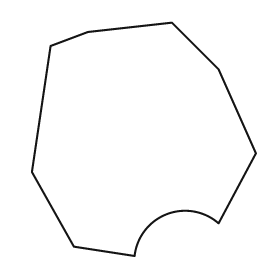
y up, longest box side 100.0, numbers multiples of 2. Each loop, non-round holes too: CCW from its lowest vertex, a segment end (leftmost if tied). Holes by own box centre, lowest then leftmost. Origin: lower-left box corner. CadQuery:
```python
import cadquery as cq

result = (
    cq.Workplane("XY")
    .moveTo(44.0, 0.0)
    .threePointArc((58.0, 18.0), (80.0, 14.0))
    .lineTo(96.0, 44.0)
    .lineTo(80.0, 80.0)
    .lineTo(60.0, 100.0)
    .lineTo(24.0, 96.0)
    .lineTo(8.0, 90.0)
    .lineTo(0.0, 36.0)
    .lineTo(18.0, 4.0)
    .close()
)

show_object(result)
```